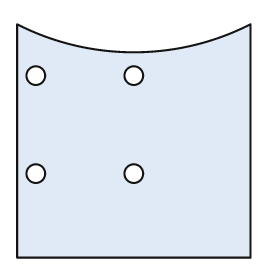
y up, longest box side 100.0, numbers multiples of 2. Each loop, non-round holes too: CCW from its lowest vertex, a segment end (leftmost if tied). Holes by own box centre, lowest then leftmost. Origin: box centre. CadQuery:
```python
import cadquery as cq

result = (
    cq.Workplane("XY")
    .moveTo(-50.0, -50.0)
    .lineTo(50.0, -50.0)
    .lineTo(50.0, 50.0)
    .threePointArc((0.0, 38.0), (-50.0, 50.0))
    .close()
    .moveTo(-42.0, -14.0)
    .circle(4.0)
    .moveTo(0.0, -14.0)
    .circle(4.0)
    .moveTo(-42.0, 28.0)
    .circle(4.0)
    .moveTo(0.0, 28.0)
    .circle(4.0)
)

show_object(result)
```